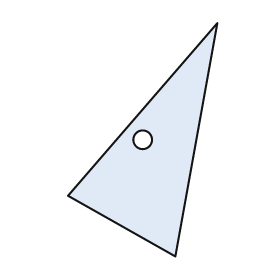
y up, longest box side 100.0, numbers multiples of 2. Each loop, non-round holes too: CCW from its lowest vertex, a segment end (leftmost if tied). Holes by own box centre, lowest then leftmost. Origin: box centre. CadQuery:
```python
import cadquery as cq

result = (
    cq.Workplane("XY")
    .moveTo(14.0, -50.0)
    .lineTo(32.0, 50.0)
    .lineTo(-32.0, -24.0)
    .close()
    .moveTo(0.0, 0.0)
    .circle(4.0)
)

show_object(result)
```